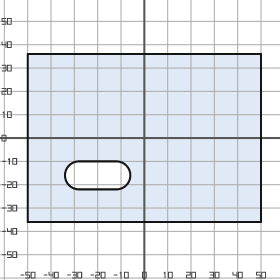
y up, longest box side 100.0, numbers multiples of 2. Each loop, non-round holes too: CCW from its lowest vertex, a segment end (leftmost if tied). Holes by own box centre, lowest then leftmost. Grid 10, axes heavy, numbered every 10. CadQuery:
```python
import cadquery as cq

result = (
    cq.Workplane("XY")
    .moveTo(-50.0, -36.0)
    .lineTo(50.0, -36.0)
    .lineTo(50.0, 36.0)
    .lineTo(-50.0, 36.0)
    .close()
    .moveTo(-28.0, -22.0)
    .lineTo(-12.0, -22.0)
    .threePointArc((-6.0, -16.0), (-12.0, -10.0))
    .lineTo(-28.0, -10.0)
    .threePointArc((-34.0, -16.0), (-28.0, -22.0))
    .close()
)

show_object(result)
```